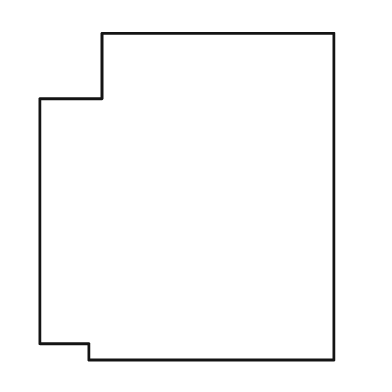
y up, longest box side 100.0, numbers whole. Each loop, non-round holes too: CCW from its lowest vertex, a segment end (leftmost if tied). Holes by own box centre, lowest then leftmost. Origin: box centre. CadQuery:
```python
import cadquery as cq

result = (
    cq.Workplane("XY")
    .moveTo(-30.0, -50.0)
    .lineTo(45.0, -50.0)
    .lineTo(45.0, 50.0)
    .lineTo(-26.0, 50.0)
    .lineTo(-26.0, 30.0)
    .lineTo(-45.0, 30.0)
    .lineTo(-45.0, -45.0)
    .lineTo(-30.0, -45.0)
    .close()
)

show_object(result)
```